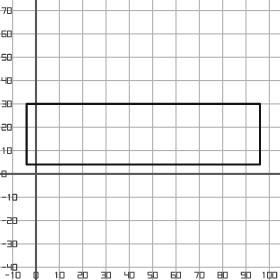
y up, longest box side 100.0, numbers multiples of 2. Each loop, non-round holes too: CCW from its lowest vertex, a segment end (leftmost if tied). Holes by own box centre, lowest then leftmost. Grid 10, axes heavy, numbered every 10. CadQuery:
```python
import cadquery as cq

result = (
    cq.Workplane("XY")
    .moveTo(-4.0, 4.0)
    .lineTo(96.0, 4.0)
    .lineTo(96.0, 30.0)
    .lineTo(-4.0, 30.0)
    .close()
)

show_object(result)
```